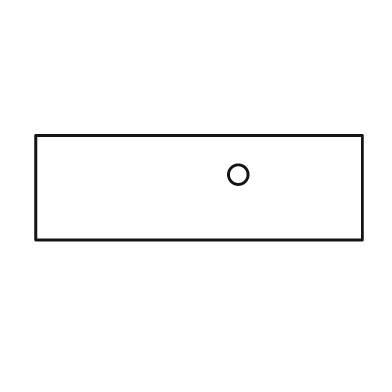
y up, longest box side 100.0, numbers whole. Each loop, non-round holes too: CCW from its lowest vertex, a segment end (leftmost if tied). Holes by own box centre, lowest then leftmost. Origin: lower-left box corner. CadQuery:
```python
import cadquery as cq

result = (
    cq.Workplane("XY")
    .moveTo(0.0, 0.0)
    .lineTo(100.0, 0.0)
    .lineTo(100.0, 32.0)
    .lineTo(0.0, 32.0)
    .close()
    .moveTo(62.0, 20.0)
    .circle(3.0)
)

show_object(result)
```